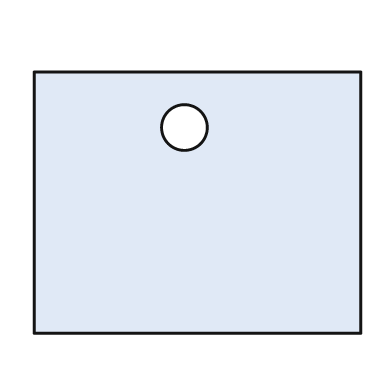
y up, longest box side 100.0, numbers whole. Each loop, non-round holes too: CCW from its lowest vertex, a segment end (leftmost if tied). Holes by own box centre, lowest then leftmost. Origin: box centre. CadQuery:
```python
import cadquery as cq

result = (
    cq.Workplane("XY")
    .moveTo(-50.0, -40.0)
    .lineTo(50.0, -40.0)
    .lineTo(50.0, 40.0)
    .lineTo(-50.0, 40.0)
    .close()
    .moveTo(-4.0, 23.0)
    .circle(7.0)
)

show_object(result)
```